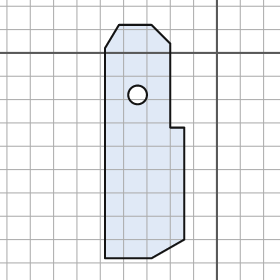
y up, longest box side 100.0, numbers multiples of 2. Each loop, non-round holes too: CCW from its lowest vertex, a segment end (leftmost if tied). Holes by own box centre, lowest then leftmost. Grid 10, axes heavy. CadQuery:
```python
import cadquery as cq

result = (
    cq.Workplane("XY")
    .moveTo(-48.0, -88.0)
    .lineTo(-28.0, -88.0)
    .lineTo(-14.0, -80.0)
    .lineTo(-14.0, -32.0)
    .lineTo(-20.0, -32.0)
    .lineTo(-20.0, 4.0)
    .lineTo(-28.0, 12.0)
    .lineTo(-42.0, 12.0)
    .lineTo(-48.0, 2.0)
    .close()
    .moveTo(-34.0, -18.0)
    .circle(4.0)
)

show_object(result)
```